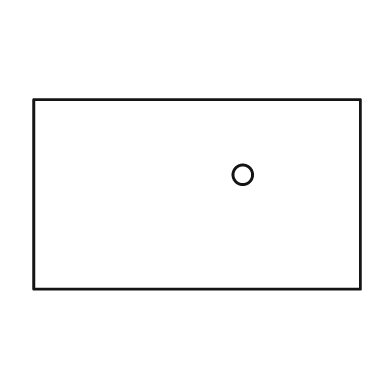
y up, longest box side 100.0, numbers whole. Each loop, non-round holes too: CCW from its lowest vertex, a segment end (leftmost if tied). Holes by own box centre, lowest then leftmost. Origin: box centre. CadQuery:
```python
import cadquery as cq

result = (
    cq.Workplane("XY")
    .moveTo(-50.0, -29.0)
    .lineTo(50.0, -29.0)
    .lineTo(50.0, 29.0)
    .lineTo(-50.0, 29.0)
    .close()
    .moveTo(14.0, 6.0)
    .circle(3.0)
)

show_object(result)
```